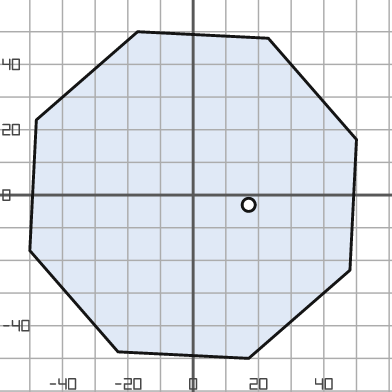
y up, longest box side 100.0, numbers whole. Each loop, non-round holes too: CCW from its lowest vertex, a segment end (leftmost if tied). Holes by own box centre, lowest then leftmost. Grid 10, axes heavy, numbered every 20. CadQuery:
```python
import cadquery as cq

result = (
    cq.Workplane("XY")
    .moveTo(17.0, -50.0)
    .lineTo(48.0, -23.0)
    .lineTo(50.0, 17.0)
    .lineTo(23.0, 48.0)
    .lineTo(-17.0, 50.0)
    .lineTo(-48.0, 23.0)
    .lineTo(-50.0, -17.0)
    .lineTo(-23.0, -48.0)
    .close()
    .moveTo(17.0, -3.0)
    .circle(2.0)
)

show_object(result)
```